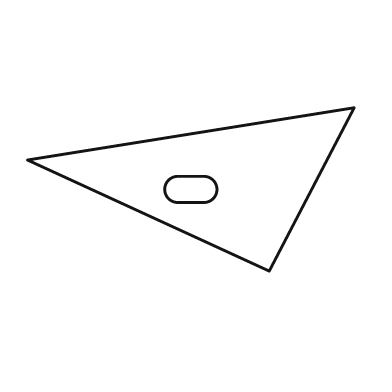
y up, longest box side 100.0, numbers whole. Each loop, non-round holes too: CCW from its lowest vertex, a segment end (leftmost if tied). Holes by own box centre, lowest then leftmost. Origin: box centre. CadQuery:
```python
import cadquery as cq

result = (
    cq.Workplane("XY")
    .moveTo(24.0, -25.0)
    .lineTo(50.0, 25.0)
    .lineTo(-50.0, 9.0)
    .close()
    .moveTo(-4.0, -4.0)
    .lineTo(4.0, -4.0)
    .threePointArc((8.0, 0.0), (4.0, 4.0))
    .lineTo(-4.0, 4.0)
    .threePointArc((-8.0, 0.0), (-4.0, -4.0))
    .close()
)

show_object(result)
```